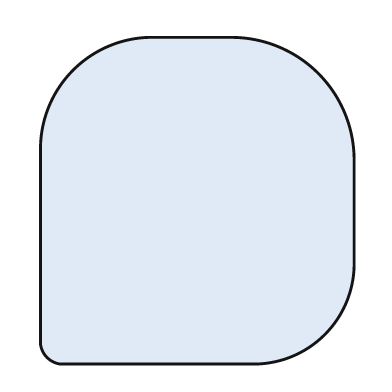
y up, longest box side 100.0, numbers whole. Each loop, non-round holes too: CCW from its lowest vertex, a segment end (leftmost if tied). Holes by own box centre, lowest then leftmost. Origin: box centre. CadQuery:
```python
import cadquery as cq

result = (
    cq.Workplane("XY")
    .moveTo(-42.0, -50.0)
    .lineTo(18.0, -50.0)
    .threePointArc((39.0, -41.0), (48.0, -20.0))
    .lineTo(48.0, 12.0)
    .threePointArc((37.0, 39.0), (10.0, 50.0))
    .lineTo(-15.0, 50.0)
    .threePointArc((-38.0, 40.0), (-48.0, 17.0))
    .lineTo(-48.0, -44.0)
    .threePointArc((-46.0, -48.0), (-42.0, -50.0))
    .close()
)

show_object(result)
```